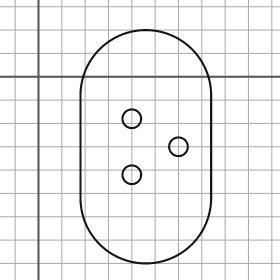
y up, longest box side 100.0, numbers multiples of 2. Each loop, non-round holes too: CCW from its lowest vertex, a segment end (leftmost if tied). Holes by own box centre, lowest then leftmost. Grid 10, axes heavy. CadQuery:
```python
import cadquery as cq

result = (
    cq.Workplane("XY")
    .moveTo(18.0, -52.0)
    .threePointArc((46.0, -80.0), (74.0, -52.0))
    .lineTo(74.0, -8.0)
    .threePointArc((46.0, 20.0), (18.0, -8.0))
    .close()
    .moveTo(40.0, -42.0)
    .circle(4.0)
    .moveTo(60.0, -30.0)
    .circle(4.0)
    .moveTo(40.0, -18.0)
    .circle(4.0)
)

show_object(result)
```